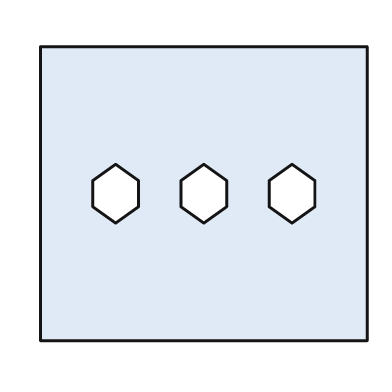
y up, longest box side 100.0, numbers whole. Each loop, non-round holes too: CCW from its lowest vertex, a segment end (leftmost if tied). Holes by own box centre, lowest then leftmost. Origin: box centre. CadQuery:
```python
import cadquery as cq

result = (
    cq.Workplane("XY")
    .moveTo(-50.0, -45.0)
    .lineTo(50.0, -45.0)
    .lineTo(50.0, 45.0)
    .lineTo(-50.0, 45.0)
    .close()
    .moveTo(-27.0, -9.0)
    .lineTo(-20.0, -4.0)
    .lineTo(-20.0, 4.0)
    .lineTo(-27.0, 9.0)
    .lineTo(-34.0, 4.0)
    .lineTo(-34.0, -4.0)
    .close()
    .moveTo(0.0, -9.0)
    .lineTo(7.0, -4.0)
    .lineTo(7.0, 4.0)
    .lineTo(0.0, 9.0)
    .lineTo(-7.0, 4.0)
    .lineTo(-7.0, -4.0)
    .close()
    .moveTo(27.0, -9.0)
    .lineTo(34.0, -4.0)
    .lineTo(34.0, 4.0)
    .lineTo(27.0, 9.0)
    .lineTo(20.0, 4.0)
    .lineTo(20.0, -4.0)
    .close()
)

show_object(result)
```